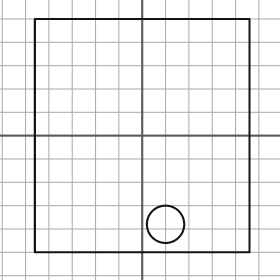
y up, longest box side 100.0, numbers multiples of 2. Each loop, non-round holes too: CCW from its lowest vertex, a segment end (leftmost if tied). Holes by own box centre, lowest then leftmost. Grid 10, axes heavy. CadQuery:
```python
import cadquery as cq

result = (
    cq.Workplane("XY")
    .moveTo(-46.0, -50.0)
    .lineTo(46.0, -50.0)
    .lineTo(46.0, 50.0)
    .lineTo(-46.0, 50.0)
    .close()
    .moveTo(10.0, -38.0)
    .circle(8.0)
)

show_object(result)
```